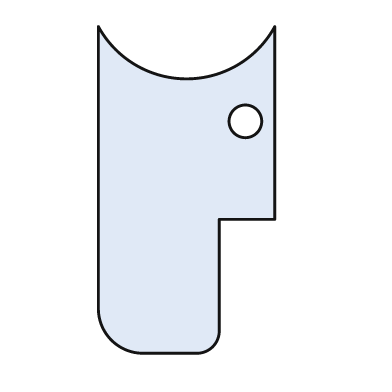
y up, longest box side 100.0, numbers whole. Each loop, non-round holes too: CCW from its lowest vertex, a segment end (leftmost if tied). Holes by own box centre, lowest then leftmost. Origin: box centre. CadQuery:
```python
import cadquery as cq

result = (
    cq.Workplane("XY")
    .moveTo(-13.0, -50.0)
    .lineTo(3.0, -50.0)
    .threePointArc((8.0, -48.0), (10.0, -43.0))
    .lineTo(10.0, -9.0)
    .lineTo(27.0, -9.0)
    .lineTo(27.0, 50.0)
    .threePointArc((0.0, 34.0), (-27.0, 50.0))
    .lineTo(-27.0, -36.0)
    .threePointArc((-23.0, -46.0), (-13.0, -50.0))
    .close()
    .moveTo(18.0, 21.0)
    .circle(5.0)
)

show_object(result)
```